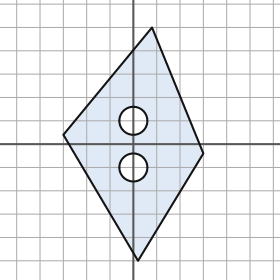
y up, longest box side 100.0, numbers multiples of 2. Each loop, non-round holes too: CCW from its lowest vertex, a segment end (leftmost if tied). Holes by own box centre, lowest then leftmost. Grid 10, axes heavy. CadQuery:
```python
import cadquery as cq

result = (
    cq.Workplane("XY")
    .moveTo(2.0, -50.0)
    .lineTo(30.0, -4.0)
    .lineTo(8.0, 50.0)
    .lineTo(-30.0, 4.0)
    .close()
    .moveTo(0.0, -10.0)
    .circle(6.0)
    .moveTo(0.0, 10.0)
    .circle(6.0)
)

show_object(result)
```